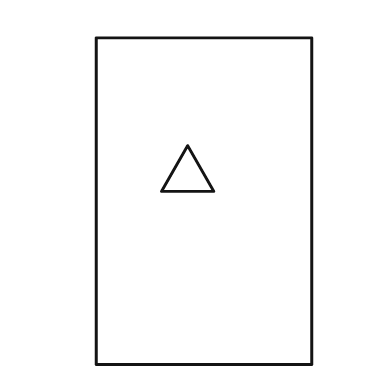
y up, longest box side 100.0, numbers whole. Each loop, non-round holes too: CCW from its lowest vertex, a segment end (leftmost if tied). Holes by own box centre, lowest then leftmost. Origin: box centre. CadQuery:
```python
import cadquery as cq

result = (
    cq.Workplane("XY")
    .moveTo(-33.0, -50.0)
    .lineTo(33.0, -50.0)
    .lineTo(33.0, 50.0)
    .lineTo(-33.0, 50.0)
    .close()
    .moveTo(-13.0, 3.0)
    .lineTo(3.0, 3.0)
    .lineTo(-5.0, 17.0)
    .close()
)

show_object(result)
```